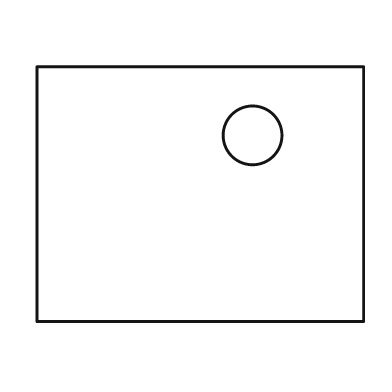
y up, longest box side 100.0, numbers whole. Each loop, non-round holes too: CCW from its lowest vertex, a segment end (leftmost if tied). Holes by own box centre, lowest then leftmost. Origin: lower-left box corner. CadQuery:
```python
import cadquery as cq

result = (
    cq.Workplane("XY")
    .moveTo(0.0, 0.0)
    .lineTo(100.0, 0.0)
    .lineTo(100.0, 78.0)
    .lineTo(0.0, 78.0)
    .close()
    .moveTo(66.0, 57.0)
    .circle(9.0)
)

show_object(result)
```